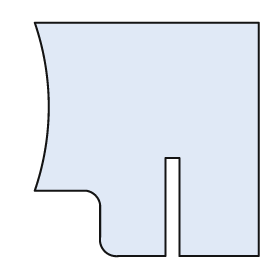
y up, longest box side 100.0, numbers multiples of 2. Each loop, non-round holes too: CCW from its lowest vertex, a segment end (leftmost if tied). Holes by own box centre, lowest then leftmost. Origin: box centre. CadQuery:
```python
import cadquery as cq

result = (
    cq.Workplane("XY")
    .moveTo(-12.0, -50.0)
    .lineTo(8.0, -50.0)
    .lineTo(8.0, -8.0)
    .lineTo(14.0, -8.0)
    .lineTo(14.0, -50.0)
    .lineTo(48.0, -50.0)
    .lineTo(48.0, 50.0)
    .lineTo(-48.0, 50.0)
    .threePointArc((-42.0, 14.0), (-48.0, -22.0))
    .lineTo(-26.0, -22.0)
    .threePointArc((-22.0, -24.0), (-20.0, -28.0))
    .lineTo(-20.0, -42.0)
    .threePointArc((-18.0, -48.0), (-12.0, -50.0))
    .close()
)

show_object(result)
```